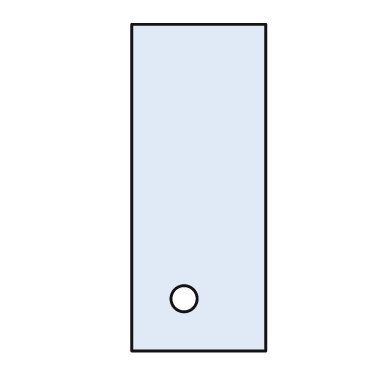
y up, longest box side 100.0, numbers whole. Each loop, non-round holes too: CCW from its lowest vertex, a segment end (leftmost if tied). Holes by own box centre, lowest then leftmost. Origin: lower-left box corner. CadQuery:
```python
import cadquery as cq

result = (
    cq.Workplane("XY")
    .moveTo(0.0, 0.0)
    .lineTo(41.0, 0.0)
    .lineTo(41.0, 100.0)
    .lineTo(0.0, 100.0)
    .close()
    .moveTo(16.0, 16.0)
    .circle(4.0)
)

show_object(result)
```